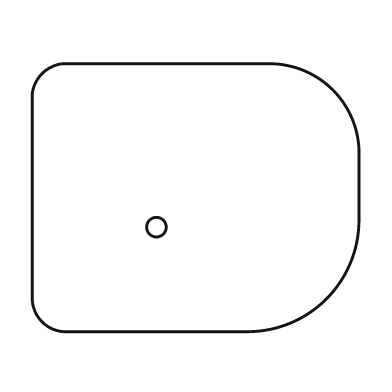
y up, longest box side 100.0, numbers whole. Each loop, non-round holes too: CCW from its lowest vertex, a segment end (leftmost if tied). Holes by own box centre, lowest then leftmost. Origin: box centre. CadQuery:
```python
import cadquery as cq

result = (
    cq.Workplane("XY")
    .moveTo(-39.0, -41.0)
    .lineTo(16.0, -41.0)
    .threePointArc((40.0, -31.0), (50.0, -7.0))
    .lineTo(50.0, 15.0)
    .threePointArc((42.0, 33.0), (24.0, 41.0))
    .lineTo(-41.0, 41.0)
    .threePointArc((-47.0, 38.0), (-50.0, 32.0))
    .lineTo(-50.0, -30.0)
    .threePointArc((-47.0, -38.0), (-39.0, -41.0))
    .close()
    .moveTo(-12.0, -9.0)
    .circle(3.0)
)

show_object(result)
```